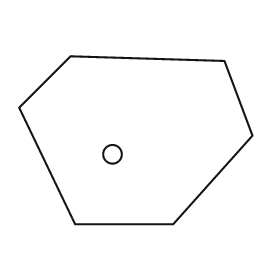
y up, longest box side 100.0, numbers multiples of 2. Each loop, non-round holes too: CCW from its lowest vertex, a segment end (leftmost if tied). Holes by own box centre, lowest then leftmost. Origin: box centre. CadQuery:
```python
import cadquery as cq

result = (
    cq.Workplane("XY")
    .moveTo(-26.0, -36.0)
    .lineTo(16.0, -36.0)
    .lineTo(50.0, 2.0)
    .lineTo(38.0, 34.0)
    .lineTo(-28.0, 36.0)
    .lineTo(-50.0, 14.0)
    .close()
    .moveTo(-10.0, -6.0)
    .circle(4.0)
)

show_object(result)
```